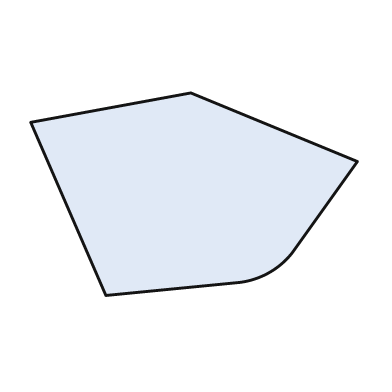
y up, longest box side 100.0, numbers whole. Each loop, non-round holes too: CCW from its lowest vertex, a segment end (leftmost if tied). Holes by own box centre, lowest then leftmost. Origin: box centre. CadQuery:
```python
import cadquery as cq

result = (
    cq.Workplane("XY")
    .moveTo(-27.0, -31.0)
    .lineTo(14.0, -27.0)
    .threePointArc((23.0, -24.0), (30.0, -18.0))
    .lineTo(50.0, 10.0)
    .lineTo(-1.0, 31.0)
    .lineTo(-50.0, 22.0)
    .close()
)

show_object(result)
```